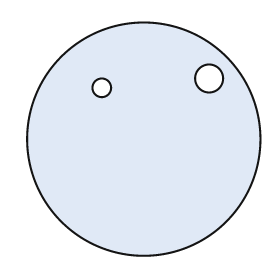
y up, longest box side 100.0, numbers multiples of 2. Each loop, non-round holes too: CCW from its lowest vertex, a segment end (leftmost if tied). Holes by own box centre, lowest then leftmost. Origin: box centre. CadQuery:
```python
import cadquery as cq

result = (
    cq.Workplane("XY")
    .moveTo(0.0, 0.0)
    .circle(50.0)
    .moveTo(-18.0, 22.0)
    .circle(4.0)
    .moveTo(28.0, 26.0)
    .circle(6.0)
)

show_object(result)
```